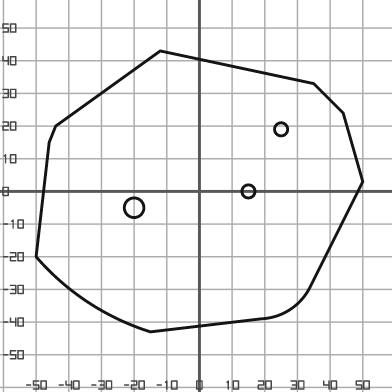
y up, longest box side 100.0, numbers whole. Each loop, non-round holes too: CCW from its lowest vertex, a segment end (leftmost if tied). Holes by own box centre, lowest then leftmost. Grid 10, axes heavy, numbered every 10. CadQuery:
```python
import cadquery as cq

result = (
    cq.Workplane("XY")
    .moveTo(-15.0, -43.0)
    .lineTo(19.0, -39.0)
    .threePointArc((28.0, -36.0), (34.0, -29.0))
    .lineTo(50.0, 3.0)
    .lineTo(44.0, 24.0)
    .lineTo(35.0, 33.0)
    .lineTo(-12.0, 43.0)
    .lineTo(-44.0, 20.0)
    .lineTo(-46.0, 15.0)
    .lineTo(-50.0, -20.0)
    .threePointArc((-34.0, -34.0), (-15.0, -43.0))
    .close()
    .moveTo(-20.0, -5.0)
    .circle(3.0)
    .moveTo(15.0, 0.0)
    .circle(2.0)
    .moveTo(25.0, 19.0)
    .circle(2.0)
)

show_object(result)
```